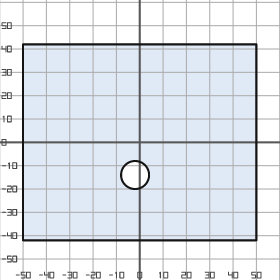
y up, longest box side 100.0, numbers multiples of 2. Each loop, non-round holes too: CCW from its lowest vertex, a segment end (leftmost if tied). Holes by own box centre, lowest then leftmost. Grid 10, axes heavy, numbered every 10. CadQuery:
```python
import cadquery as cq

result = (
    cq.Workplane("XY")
    .moveTo(-50.0, -42.0)
    .lineTo(50.0, -42.0)
    .lineTo(50.0, 42.0)
    .lineTo(-50.0, 42.0)
    .close()
    .moveTo(-2.0, -14.0)
    .circle(6.0)
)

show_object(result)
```